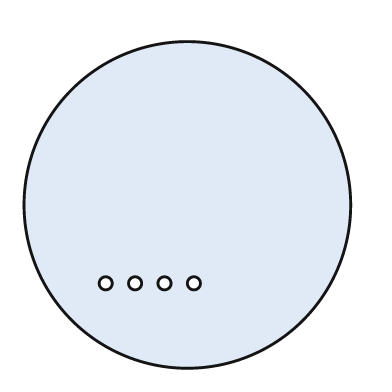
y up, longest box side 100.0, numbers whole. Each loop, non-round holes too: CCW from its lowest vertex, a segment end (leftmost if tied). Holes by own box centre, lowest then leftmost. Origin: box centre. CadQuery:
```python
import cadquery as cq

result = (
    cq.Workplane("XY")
    .moveTo(0.0, 0.0)
    .circle(50.0)
    .moveTo(-25.0, -24.0)
    .circle(2.0)
    .moveTo(-16.0, -24.0)
    .circle(2.0)
    .moveTo(-7.0, -24.0)
    .circle(2.0)
    .moveTo(2.0, -24.0)
    .circle(2.0)
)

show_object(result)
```